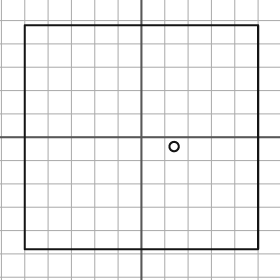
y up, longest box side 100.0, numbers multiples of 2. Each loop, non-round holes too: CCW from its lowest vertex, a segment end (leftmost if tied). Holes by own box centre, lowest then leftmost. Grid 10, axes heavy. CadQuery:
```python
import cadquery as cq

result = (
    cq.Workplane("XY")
    .moveTo(-50.0, -48.0)
    .lineTo(50.0, -48.0)
    .lineTo(50.0, 48.0)
    .lineTo(-50.0, 48.0)
    .close()
    .moveTo(14.0, -4.0)
    .circle(2.0)
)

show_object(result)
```